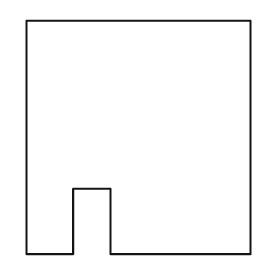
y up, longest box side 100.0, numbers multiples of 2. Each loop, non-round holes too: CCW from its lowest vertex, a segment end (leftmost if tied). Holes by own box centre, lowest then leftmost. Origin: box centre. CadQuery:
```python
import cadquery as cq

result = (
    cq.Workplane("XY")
    .moveTo(-48.0, -50.0)
    .lineTo(-28.0, -50.0)
    .lineTo(-28.0, -22.0)
    .lineTo(-12.0, -22.0)
    .lineTo(-12.0, -50.0)
    .lineTo(48.0, -50.0)
    .lineTo(48.0, 50.0)
    .lineTo(-48.0, 50.0)
    .close()
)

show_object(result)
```